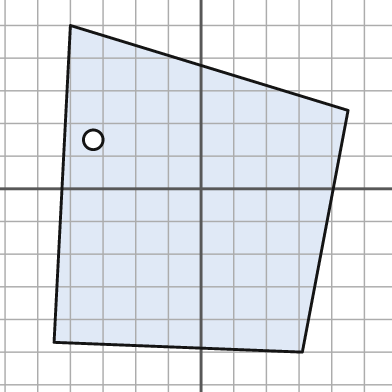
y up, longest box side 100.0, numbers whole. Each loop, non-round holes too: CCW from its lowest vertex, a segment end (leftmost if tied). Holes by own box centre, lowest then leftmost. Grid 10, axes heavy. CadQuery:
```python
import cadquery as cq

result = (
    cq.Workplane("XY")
    .moveTo(31.0, -50.0)
    .lineTo(45.0, 24.0)
    .lineTo(-40.0, 50.0)
    .lineTo(-45.0, -47.0)
    .close()
    .moveTo(-33.0, 15.0)
    .circle(3.0)
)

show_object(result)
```